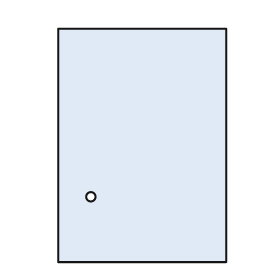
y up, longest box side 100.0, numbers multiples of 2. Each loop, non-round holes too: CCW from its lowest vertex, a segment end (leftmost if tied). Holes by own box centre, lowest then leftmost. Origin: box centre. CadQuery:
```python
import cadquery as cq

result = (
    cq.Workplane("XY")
    .moveTo(-36.0, -50.0)
    .lineTo(36.0, -50.0)
    .lineTo(36.0, 50.0)
    .lineTo(-36.0, 50.0)
    .close()
    .moveTo(-22.0, -22.0)
    .circle(2.0)
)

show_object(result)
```